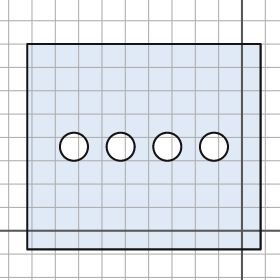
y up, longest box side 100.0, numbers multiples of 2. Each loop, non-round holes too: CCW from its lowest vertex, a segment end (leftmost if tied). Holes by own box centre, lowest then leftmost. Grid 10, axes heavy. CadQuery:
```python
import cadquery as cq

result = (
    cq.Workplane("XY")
    .moveTo(-92.0, -8.0)
    .lineTo(8.0, -8.0)
    .lineTo(8.0, 80.0)
    .lineTo(-92.0, 80.0)
    .close()
    .moveTo(-72.0, 36.0)
    .circle(6.0)
    .moveTo(-52.0, 36.0)
    .circle(6.0)
    .moveTo(-32.0, 36.0)
    .circle(6.0)
    .moveTo(-12.0, 36.0)
    .circle(6.0)
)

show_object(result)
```